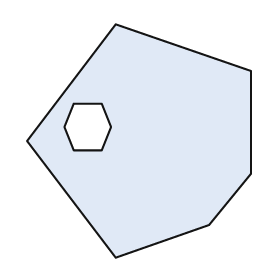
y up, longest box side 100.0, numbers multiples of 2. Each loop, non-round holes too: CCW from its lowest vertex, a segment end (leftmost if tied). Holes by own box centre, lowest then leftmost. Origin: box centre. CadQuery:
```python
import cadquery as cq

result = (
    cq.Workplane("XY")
    .moveTo(-10.0, -50.0)
    .lineTo(30.0, -36.0)
    .lineTo(48.0, -14.0)
    .lineTo(48.0, 30.0)
    .lineTo(-10.0, 50.0)
    .lineTo(-48.0, 0.0)
    .close()
    .moveTo(-28.0, -4.0)
    .lineTo(-16.0, -4.0)
    .lineTo(-12.0, 6.0)
    .lineTo(-16.0, 16.0)
    .lineTo(-28.0, 16.0)
    .lineTo(-32.0, 6.0)
    .close()
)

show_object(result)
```